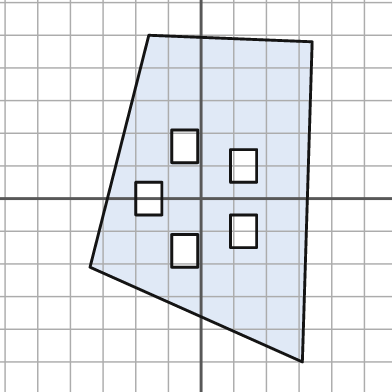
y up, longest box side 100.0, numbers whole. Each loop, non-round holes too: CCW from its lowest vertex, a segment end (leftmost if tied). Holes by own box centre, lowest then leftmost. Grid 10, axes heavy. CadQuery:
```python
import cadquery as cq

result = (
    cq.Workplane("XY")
    .moveTo(31.0, -50.0)
    .lineTo(34.0, 48.0)
    .lineTo(-16.0, 50.0)
    .lineTo(-34.0, -21.0)
    .close()
    .moveTo(-9.0, -21.0)
    .lineTo(-1.0, -21.0)
    .lineTo(-1.0, -11.0)
    .lineTo(-9.0, -11.0)
    .close()
    .moveTo(9.0, -15.0)
    .lineTo(17.0, -15.0)
    .lineTo(17.0, -5.0)
    .lineTo(9.0, -5.0)
    .close()
    .moveTo(-20.0, -5.0)
    .lineTo(-12.0, -5.0)
    .lineTo(-12.0, 5.0)
    .lineTo(-20.0, 5.0)
    .close()
    .moveTo(9.0, 5.0)
    .lineTo(17.0, 5.0)
    .lineTo(17.0, 15.0)
    .lineTo(9.0, 15.0)
    .close()
    .moveTo(-9.0, 11.0)
    .lineTo(-1.0, 11.0)
    .lineTo(-1.0, 21.0)
    .lineTo(-9.0, 21.0)
    .close()
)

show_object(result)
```